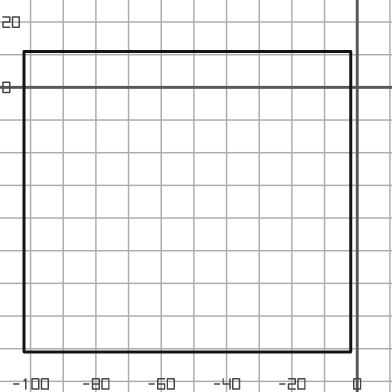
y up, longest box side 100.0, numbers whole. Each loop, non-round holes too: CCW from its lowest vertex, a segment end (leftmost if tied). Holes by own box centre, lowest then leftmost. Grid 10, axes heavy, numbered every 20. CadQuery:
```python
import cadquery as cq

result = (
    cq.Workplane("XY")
    .moveTo(-102.0, -81.0)
    .lineTo(-2.0, -81.0)
    .lineTo(-2.0, 11.0)
    .lineTo(-102.0, 11.0)
    .close()
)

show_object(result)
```